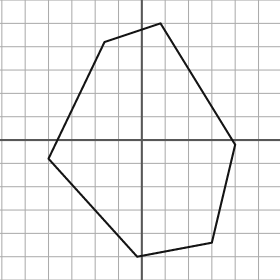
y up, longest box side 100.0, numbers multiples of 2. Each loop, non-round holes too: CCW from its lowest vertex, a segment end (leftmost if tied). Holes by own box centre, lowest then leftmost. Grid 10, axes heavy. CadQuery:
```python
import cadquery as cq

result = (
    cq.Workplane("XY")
    .moveTo(-2.0, -50.0)
    .lineTo(30.0, -44.0)
    .lineTo(40.0, -2.0)
    .lineTo(8.0, 50.0)
    .lineTo(-16.0, 42.0)
    .lineTo(-40.0, -8.0)
    .close()
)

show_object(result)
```